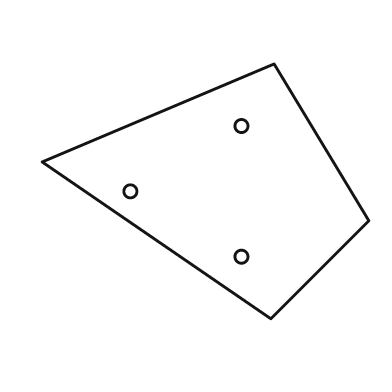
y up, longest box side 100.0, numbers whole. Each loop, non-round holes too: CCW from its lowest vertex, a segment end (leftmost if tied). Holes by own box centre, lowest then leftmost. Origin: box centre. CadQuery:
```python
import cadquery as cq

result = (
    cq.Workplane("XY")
    .moveTo(20.0, -39.0)
    .lineTo(50.0, -9.0)
    .lineTo(21.0, 39.0)
    .lineTo(-50.0, 9.0)
    .close()
    .moveTo(11.0, -20.0)
    .circle(2.0)
    .moveTo(-23.0, 0.0)
    .circle(2.0)
    .moveTo(11.0, 20.0)
    .circle(2.0)
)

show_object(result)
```